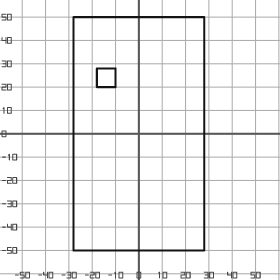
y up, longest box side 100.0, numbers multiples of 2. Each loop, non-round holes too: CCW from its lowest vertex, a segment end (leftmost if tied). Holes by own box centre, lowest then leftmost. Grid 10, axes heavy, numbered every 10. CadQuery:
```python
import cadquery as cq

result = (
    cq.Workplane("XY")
    .moveTo(-28.0, -50.0)
    .lineTo(28.0, -50.0)
    .lineTo(28.0, 50.0)
    .lineTo(-28.0, 50.0)
    .close()
    .moveTo(-18.0, 20.0)
    .lineTo(-10.0, 20.0)
    .lineTo(-10.0, 28.0)
    .lineTo(-18.0, 28.0)
    .close()
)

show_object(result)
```